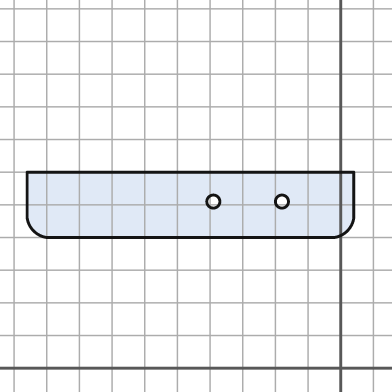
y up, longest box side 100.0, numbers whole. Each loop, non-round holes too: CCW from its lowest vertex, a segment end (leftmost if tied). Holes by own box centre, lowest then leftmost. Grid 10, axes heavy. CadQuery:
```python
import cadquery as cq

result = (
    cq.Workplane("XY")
    .moveTo(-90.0, 40.0)
    .lineTo(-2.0, 40.0)
    .threePointArc((2.0, 42.0), (4.0, 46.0))
    .lineTo(4.0, 60.0)
    .lineTo(-96.0, 60.0)
    .lineTo(-96.0, 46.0)
    .threePointArc((-94.0, 42.0), (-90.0, 40.0))
    .close()
    .moveTo(-39.0, 51.0)
    .circle(2.0)
    .moveTo(-18.0, 51.0)
    .circle(2.0)
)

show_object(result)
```